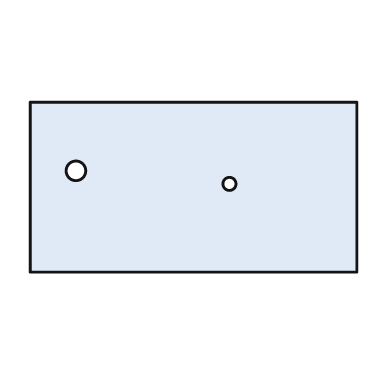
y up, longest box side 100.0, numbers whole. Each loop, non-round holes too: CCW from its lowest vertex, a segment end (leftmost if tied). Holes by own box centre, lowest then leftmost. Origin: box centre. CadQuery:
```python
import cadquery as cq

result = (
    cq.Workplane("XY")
    .moveTo(-50.0, -26.0)
    .lineTo(50.0, -26.0)
    .lineTo(50.0, 26.0)
    .lineTo(-50.0, 26.0)
    .close()
    .moveTo(11.0, 1.0)
    .circle(2.0)
    .moveTo(-36.0, 5.0)
    .circle(3.0)
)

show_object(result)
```